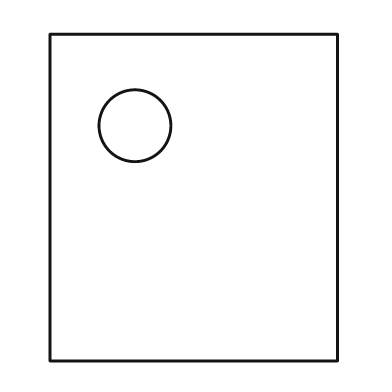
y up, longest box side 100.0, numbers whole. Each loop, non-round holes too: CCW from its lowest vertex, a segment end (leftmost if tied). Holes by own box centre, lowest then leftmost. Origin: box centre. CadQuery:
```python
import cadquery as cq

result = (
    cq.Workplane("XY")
    .moveTo(-44.0, -50.0)
    .lineTo(44.0, -50.0)
    .lineTo(44.0, 50.0)
    .lineTo(-44.0, 50.0)
    .close()
    .moveTo(-18.0, 22.0)
    .circle(11.0)
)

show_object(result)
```